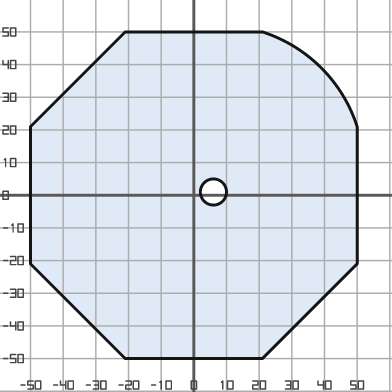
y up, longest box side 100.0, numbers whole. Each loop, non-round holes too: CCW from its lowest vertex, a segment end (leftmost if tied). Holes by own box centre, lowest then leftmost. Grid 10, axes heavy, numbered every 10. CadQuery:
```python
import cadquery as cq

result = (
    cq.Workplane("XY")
    .moveTo(-21.0, -50.0)
    .lineTo(21.0, -50.0)
    .lineTo(50.0, -21.0)
    .lineTo(50.0, 21.0)
    .threePointArc((39.0, 39.0), (21.0, 50.0))
    .lineTo(-21.0, 50.0)
    .lineTo(-50.0, 21.0)
    .lineTo(-50.0, -21.0)
    .close()
    .moveTo(6.0, 1.0)
    .circle(4.0)
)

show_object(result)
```